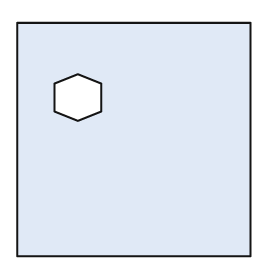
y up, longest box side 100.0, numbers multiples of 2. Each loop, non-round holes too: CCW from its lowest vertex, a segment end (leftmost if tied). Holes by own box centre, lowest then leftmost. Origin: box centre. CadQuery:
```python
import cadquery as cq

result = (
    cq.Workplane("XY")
    .moveTo(-50.0, -50.0)
    .lineTo(50.0, -50.0)
    .lineTo(50.0, 50.0)
    .lineTo(-50.0, 50.0)
    .close()
    .moveTo(-24.0, 8.0)
    .lineTo(-14.0, 12.0)
    .lineTo(-14.0, 24.0)
    .lineTo(-24.0, 28.0)
    .lineTo(-34.0, 24.0)
    .lineTo(-34.0, 12.0)
    .close()
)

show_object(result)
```